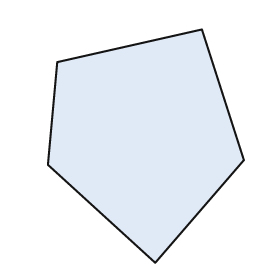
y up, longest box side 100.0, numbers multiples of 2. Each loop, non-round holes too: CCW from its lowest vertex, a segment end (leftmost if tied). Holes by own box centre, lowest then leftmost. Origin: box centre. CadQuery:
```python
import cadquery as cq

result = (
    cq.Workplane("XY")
    .moveTo(4.0, -50.0)
    .lineTo(42.0, -6.0)
    .lineTo(24.0, 50.0)
    .lineTo(-38.0, 36.0)
    .lineTo(-42.0, -8.0)
    .close()
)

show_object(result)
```